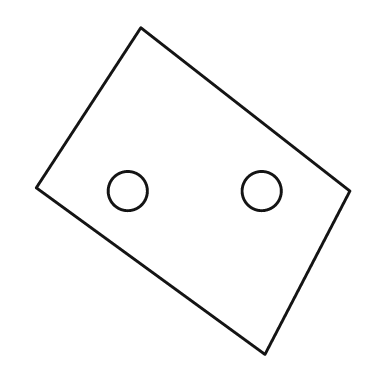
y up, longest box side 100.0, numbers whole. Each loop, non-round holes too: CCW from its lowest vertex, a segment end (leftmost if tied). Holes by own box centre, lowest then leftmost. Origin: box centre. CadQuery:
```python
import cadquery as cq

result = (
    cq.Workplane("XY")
    .moveTo(22.0, -50.0)
    .lineTo(48.0, 0.0)
    .lineTo(-16.0, 50.0)
    .lineTo(-48.0, 1.0)
    .close()
    .moveTo(-20.0, 0.0)
    .circle(6.0)
    .moveTo(21.0, 0.0)
    .circle(6.0)
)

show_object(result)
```